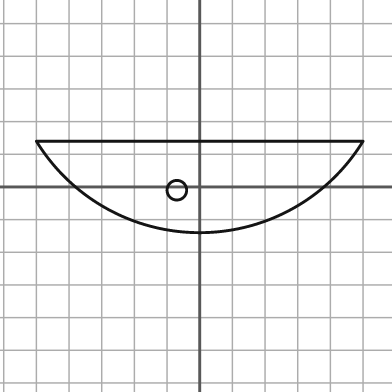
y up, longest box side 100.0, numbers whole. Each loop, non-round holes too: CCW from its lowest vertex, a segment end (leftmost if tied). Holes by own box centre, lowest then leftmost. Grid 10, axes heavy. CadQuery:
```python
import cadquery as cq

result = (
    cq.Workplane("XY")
    .moveTo(-50.0, 14.0)
    .threePointArc((0.0, -14.0), (50.0, 14.0))
    .close()
    .moveTo(-7.0, -1.0)
    .circle(3.0)
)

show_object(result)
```